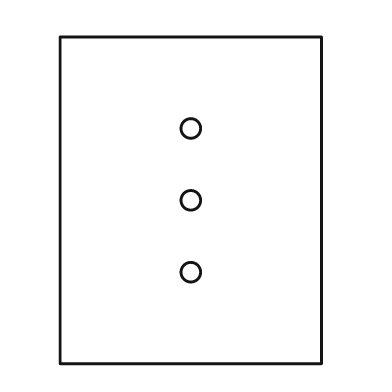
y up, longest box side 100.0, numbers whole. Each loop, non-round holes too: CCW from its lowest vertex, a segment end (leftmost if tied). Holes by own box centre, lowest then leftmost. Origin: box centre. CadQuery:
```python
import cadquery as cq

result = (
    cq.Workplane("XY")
    .moveTo(-40.0, -50.0)
    .lineTo(40.0, -50.0)
    .lineTo(40.0, 50.0)
    .lineTo(-40.0, 50.0)
    .close()
    .moveTo(0.0, -22.0)
    .circle(3.0)
    .moveTo(0.0, 0.0)
    .circle(3.0)
    .moveTo(0.0, 22.0)
    .circle(3.0)
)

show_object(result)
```